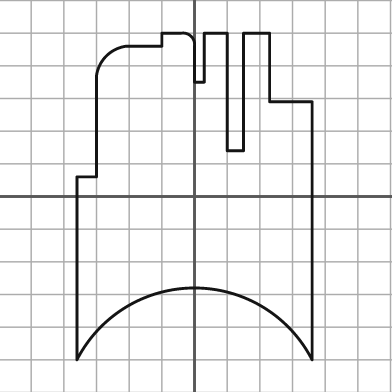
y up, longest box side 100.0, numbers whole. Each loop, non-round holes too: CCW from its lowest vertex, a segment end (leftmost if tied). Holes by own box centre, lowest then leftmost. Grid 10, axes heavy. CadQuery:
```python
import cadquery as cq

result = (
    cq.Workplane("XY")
    .moveTo(-36.0, -50.0)
    .threePointArc((0.0, -28.0), (36.0, -50.0))
    .lineTo(36.0, 29.0)
    .lineTo(23.0, 29.0)
    .lineTo(23.0, 50.0)
    .lineTo(15.0, 50.0)
    .lineTo(15.0, 14.0)
    .lineTo(10.0, 14.0)
    .lineTo(10.0, 50.0)
    .lineTo(3.0, 50.0)
    .lineTo(3.0, 35.0)
    .lineTo(0.0, 35.0)
    .lineTo(0.0, 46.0)
    .threePointArc((-1.0, 49.0), (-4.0, 50.0))
    .lineTo(-10.0, 50.0)
    .lineTo(-10.0, 46.0)
    .lineTo(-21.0, 46.0)
    .threePointArc((-27.0, 43.0), (-30.0, 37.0))
    .lineTo(-30.0, 6.0)
    .lineTo(-36.0, 6.0)
    .close()
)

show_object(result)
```